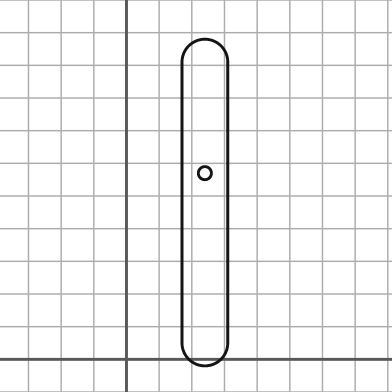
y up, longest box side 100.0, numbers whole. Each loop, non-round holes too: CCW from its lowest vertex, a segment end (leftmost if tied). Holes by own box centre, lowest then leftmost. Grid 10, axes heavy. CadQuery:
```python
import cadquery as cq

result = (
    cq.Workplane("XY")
    .moveTo(17.0, 5.0)
    .threePointArc((24.0, -2.0), (31.0, 5.0))
    .lineTo(31.0, 91.0)
    .threePointArc((24.0, 98.0), (17.0, 91.0))
    .close()
    .moveTo(24.0, 57.0)
    .circle(2.0)
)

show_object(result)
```